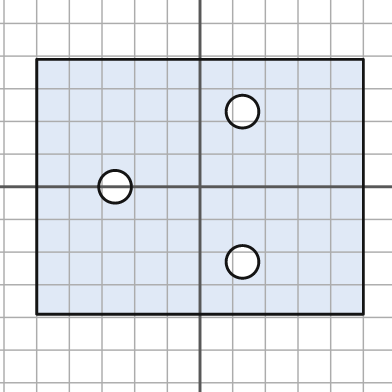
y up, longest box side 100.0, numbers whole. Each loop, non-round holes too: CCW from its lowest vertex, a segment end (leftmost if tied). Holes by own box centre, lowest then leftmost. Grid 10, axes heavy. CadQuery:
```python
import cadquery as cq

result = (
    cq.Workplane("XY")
    .moveTo(-50.0, -39.0)
    .lineTo(50.0, -39.0)
    .lineTo(50.0, 39.0)
    .lineTo(-50.0, 39.0)
    .close()
    .moveTo(13.0, -23.0)
    .circle(5.0)
    .moveTo(-26.0, 0.0)
    .circle(5.0)
    .moveTo(13.0, 23.0)
    .circle(5.0)
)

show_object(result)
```